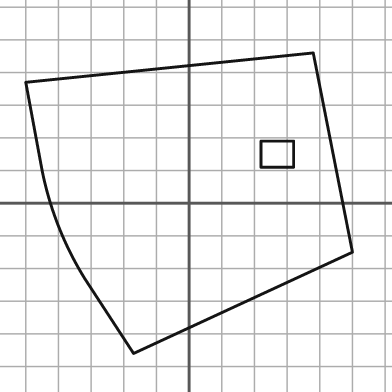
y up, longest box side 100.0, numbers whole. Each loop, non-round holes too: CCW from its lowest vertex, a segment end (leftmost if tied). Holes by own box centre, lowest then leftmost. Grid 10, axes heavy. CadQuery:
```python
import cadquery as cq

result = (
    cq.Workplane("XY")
    .moveTo(-17.0, -46.0)
    .lineTo(50.0, -15.0)
    .lineTo(38.0, 46.0)
    .lineTo(-50.0, 37.0)
    .lineTo(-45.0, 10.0)
    .threePointArc((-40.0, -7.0), (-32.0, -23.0))
    .close()
    .moveTo(22.0, 11.0)
    .lineTo(32.0, 11.0)
    .lineTo(32.0, 19.0)
    .lineTo(22.0, 19.0)
    .close()
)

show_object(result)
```